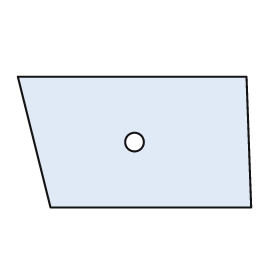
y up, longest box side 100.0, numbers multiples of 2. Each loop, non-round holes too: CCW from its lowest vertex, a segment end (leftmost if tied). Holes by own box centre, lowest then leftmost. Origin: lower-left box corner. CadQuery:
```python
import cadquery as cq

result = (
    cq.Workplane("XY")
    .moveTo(14.0, 0.0)
    .lineTo(100.0, 0.0)
    .lineTo(98.0, 56.0)
    .lineTo(0.0, 56.0)
    .close()
    .moveTo(50.0, 28.0)
    .circle(4.0)
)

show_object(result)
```